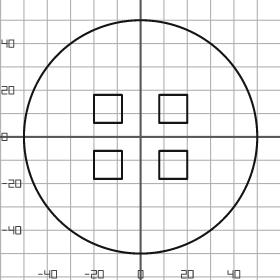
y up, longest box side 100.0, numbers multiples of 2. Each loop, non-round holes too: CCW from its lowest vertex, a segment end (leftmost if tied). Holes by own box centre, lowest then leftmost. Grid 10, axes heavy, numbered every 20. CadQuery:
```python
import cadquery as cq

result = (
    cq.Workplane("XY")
    .moveTo(0.0, 0.0)
    .circle(50.0)
    .moveTo(-20.0, -18.0)
    .lineTo(-8.0, -18.0)
    .lineTo(-8.0, -6.0)
    .lineTo(-20.0, -6.0)
    .close()
    .moveTo(8.0, -18.0)
    .lineTo(20.0, -18.0)
    .lineTo(20.0, -6.0)
    .lineTo(8.0, -6.0)
    .close()
    .moveTo(-20.0, 6.0)
    .lineTo(-8.0, 6.0)
    .lineTo(-8.0, 18.0)
    .lineTo(-20.0, 18.0)
    .close()
    .moveTo(8.0, 6.0)
    .lineTo(20.0, 6.0)
    .lineTo(20.0, 18.0)
    .lineTo(8.0, 18.0)
    .close()
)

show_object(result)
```